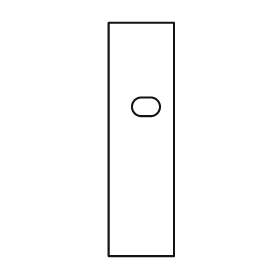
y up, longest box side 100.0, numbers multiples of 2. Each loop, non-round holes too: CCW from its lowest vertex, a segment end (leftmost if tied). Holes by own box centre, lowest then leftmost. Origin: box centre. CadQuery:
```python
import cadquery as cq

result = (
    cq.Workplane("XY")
    .moveTo(-14.0, -50.0)
    .lineTo(14.0, -50.0)
    .lineTo(14.0, 50.0)
    .lineTo(-14.0, 50.0)
    .close()
    .moveTo(0.0, 10.0)
    .lineTo(4.0, 10.0)
    .threePointArc((8.0, 14.0), (4.0, 18.0))
    .lineTo(0.0, 18.0)
    .threePointArc((-4.0, 14.0), (0.0, 10.0))
    .close()
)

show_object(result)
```